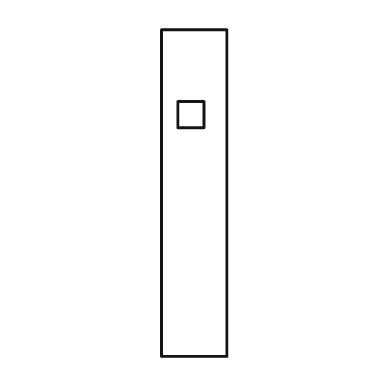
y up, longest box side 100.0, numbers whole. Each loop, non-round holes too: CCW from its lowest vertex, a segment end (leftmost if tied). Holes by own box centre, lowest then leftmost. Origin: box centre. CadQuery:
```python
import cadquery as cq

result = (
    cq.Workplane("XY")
    .moveTo(-10.0, -50.0)
    .lineTo(10.0, -50.0)
    .lineTo(10.0, 50.0)
    .lineTo(-10.0, 50.0)
    .close()
    .moveTo(-5.0, 20.0)
    .lineTo(3.0, 20.0)
    .lineTo(3.0, 28.0)
    .lineTo(-5.0, 28.0)
    .close()
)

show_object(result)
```